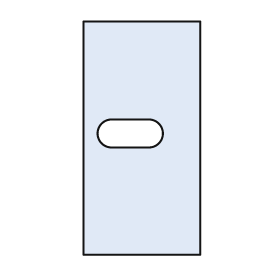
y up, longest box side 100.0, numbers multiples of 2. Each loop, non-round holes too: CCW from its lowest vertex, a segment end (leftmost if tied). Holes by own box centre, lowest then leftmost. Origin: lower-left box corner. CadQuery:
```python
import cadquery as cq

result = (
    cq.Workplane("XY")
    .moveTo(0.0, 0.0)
    .lineTo(50.0, 0.0)
    .lineTo(50.0, 100.0)
    .lineTo(0.0, 100.0)
    .close()
    .moveTo(12.0, 46.0)
    .lineTo(28.0, 46.0)
    .threePointArc((34.0, 52.0), (28.0, 58.0))
    .lineTo(12.0, 58.0)
    .threePointArc((6.0, 52.0), (12.0, 46.0))
    .close()
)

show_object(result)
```